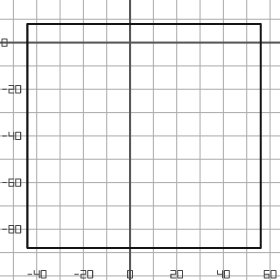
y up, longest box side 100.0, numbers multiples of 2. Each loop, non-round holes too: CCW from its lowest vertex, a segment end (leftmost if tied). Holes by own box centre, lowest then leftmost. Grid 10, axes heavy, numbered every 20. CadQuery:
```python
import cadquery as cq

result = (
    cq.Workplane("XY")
    .moveTo(-44.0, -88.0)
    .lineTo(56.0, -88.0)
    .lineTo(56.0, 8.0)
    .lineTo(-44.0, 8.0)
    .close()
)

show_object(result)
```